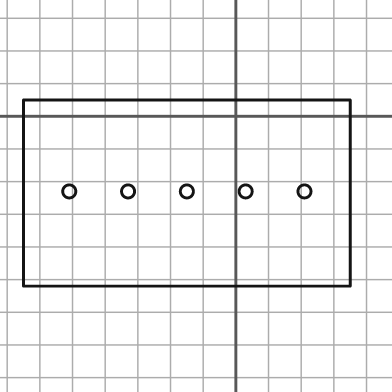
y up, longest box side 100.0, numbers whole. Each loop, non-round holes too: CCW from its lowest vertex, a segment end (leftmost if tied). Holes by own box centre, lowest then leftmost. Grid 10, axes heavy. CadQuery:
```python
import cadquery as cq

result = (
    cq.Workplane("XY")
    .moveTo(-65.0, -52.0)
    .lineTo(35.0, -52.0)
    .lineTo(35.0, 5.0)
    .lineTo(-65.0, 5.0)
    .close()
    .moveTo(-51.0, -23.0)
    .circle(2.0)
    .moveTo(-33.0, -23.0)
    .circle(2.0)
    .moveTo(-15.0, -23.0)
    .circle(2.0)
    .moveTo(3.0, -23.0)
    .circle(2.0)
    .moveTo(21.0, -23.0)
    .circle(2.0)
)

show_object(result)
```